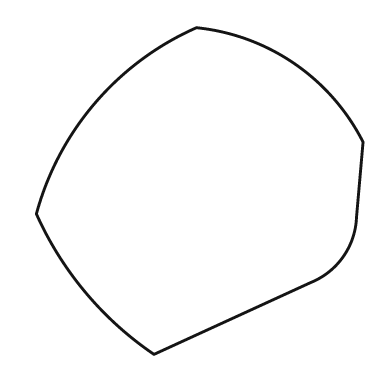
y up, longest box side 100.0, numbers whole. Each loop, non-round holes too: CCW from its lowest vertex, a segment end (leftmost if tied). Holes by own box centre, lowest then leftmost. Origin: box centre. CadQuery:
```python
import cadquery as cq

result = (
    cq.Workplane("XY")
    .moveTo(-14.0, -50.0)
    .lineTo(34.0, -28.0)
    .threePointArc((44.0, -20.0), (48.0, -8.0))
    .lineTo(50.0, 15.0)
    .threePointArc((29.0, 39.0), (-1.0, 50.0))
    .threePointArc((-32.0, 27.0), (-50.0, -7.0))
    .threePointArc((-35.0, -31.0), (-14.0, -50.0))
    .close()
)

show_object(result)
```